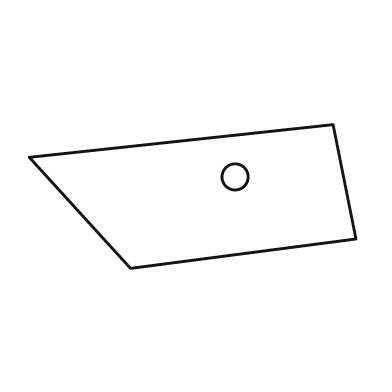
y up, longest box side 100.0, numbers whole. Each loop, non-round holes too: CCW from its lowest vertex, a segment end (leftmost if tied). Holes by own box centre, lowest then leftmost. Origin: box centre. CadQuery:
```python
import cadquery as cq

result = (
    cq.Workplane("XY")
    .moveTo(-19.0, -22.0)
    .lineTo(50.0, -13.0)
    .lineTo(43.0, 22.0)
    .lineTo(-50.0, 12.0)
    .close()
    .moveTo(13.0, 6.0)
    .circle(4.0)
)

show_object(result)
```